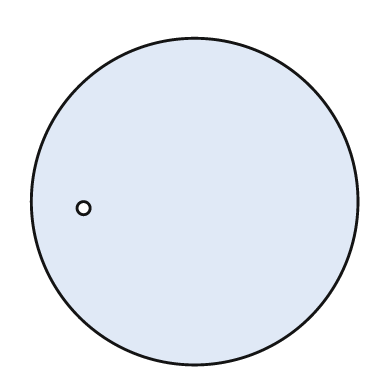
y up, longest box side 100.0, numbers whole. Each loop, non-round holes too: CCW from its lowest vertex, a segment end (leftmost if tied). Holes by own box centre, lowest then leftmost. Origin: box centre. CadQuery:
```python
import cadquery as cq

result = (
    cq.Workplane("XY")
    .moveTo(0.0, 0.0)
    .circle(50.0)
    .moveTo(-34.0, -2.0)
    .circle(2.0)
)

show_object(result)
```